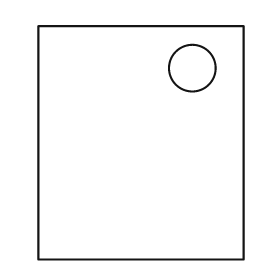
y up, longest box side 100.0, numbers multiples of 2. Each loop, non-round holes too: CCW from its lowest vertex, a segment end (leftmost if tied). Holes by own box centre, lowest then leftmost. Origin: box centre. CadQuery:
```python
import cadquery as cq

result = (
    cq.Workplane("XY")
    .moveTo(-44.0, -50.0)
    .lineTo(44.0, -50.0)
    .lineTo(44.0, 50.0)
    .lineTo(-44.0, 50.0)
    .close()
    .moveTo(22.0, 32.0)
    .circle(10.0)
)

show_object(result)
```